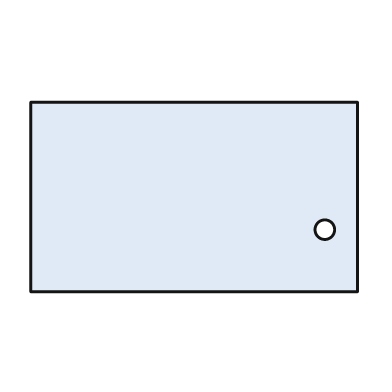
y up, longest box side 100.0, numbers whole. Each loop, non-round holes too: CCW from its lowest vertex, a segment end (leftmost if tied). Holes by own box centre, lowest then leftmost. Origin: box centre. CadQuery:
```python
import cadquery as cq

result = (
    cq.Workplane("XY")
    .moveTo(-50.0, -29.0)
    .lineTo(50.0, -29.0)
    .lineTo(50.0, 29.0)
    .lineTo(-50.0, 29.0)
    .close()
    .moveTo(40.0, -10.0)
    .circle(3.0)
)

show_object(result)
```